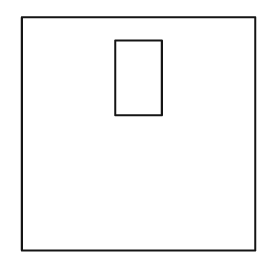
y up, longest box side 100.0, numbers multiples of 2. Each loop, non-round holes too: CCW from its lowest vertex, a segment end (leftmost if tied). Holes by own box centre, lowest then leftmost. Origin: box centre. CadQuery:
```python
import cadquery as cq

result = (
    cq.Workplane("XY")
    .moveTo(-50.0, -50.0)
    .lineTo(50.0, -50.0)
    .lineTo(50.0, 50.0)
    .lineTo(-50.0, 50.0)
    .close()
    .moveTo(-10.0, 8.0)
    .lineTo(10.0, 8.0)
    .lineTo(10.0, 40.0)
    .lineTo(-10.0, 40.0)
    .close()
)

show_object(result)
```